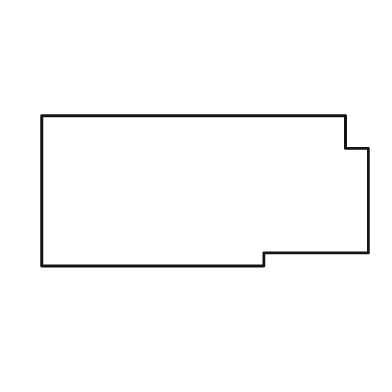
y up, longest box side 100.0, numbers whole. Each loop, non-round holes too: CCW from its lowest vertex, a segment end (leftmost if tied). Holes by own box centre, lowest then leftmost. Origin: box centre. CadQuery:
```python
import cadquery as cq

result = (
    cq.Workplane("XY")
    .moveTo(-50.0, -23.0)
    .lineTo(18.0, -23.0)
    .lineTo(18.0, -19.0)
    .lineTo(50.0, -19.0)
    .lineTo(50.0, 13.0)
    .lineTo(43.0, 13.0)
    .lineTo(43.0, 23.0)
    .lineTo(-50.0, 23.0)
    .close()
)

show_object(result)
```